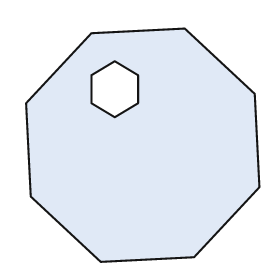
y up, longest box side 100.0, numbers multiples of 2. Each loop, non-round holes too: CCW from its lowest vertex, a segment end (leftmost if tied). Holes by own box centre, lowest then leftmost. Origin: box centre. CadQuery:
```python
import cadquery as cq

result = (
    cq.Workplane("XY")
    .moveTo(-18.0, -50.0)
    .lineTo(22.0, -48.0)
    .lineTo(50.0, -18.0)
    .lineTo(48.0, 22.0)
    .lineTo(18.0, 50.0)
    .lineTo(-22.0, 48.0)
    .lineTo(-50.0, 18.0)
    .lineTo(-48.0, -22.0)
    .close()
    .moveTo(-12.0, 12.0)
    .lineTo(-2.0, 18.0)
    .lineTo(-2.0, 30.0)
    .lineTo(-12.0, 36.0)
    .lineTo(-22.0, 30.0)
    .lineTo(-22.0, 18.0)
    .close()
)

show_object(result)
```